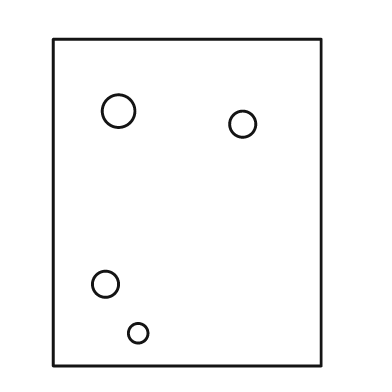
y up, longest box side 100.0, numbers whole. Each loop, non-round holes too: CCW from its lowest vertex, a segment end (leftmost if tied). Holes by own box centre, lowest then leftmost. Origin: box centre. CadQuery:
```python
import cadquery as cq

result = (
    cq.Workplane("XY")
    .moveTo(-41.0, -50.0)
    .lineTo(41.0, -50.0)
    .lineTo(41.0, 50.0)
    .lineTo(-41.0, 50.0)
    .close()
    .moveTo(-15.0, -40.0)
    .circle(3.0)
    .moveTo(-25.0, -25.0)
    .circle(4.0)
    .moveTo(17.0, 24.0)
    .circle(4.0)
    .moveTo(-21.0, 28.0)
    .circle(5.0)
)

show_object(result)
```